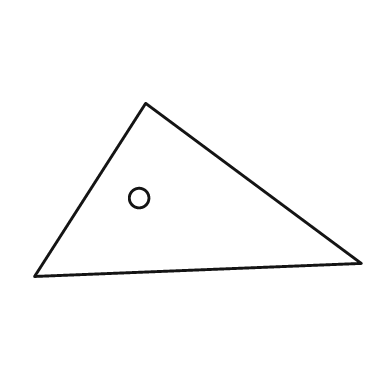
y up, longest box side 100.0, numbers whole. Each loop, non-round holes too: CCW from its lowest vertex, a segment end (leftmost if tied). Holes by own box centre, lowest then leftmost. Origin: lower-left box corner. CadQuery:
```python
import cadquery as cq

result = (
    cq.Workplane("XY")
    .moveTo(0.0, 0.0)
    .lineTo(100.0, 4.0)
    .lineTo(34.0, 53.0)
    .close()
    .moveTo(32.0, 24.0)
    .circle(3.0)
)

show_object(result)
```